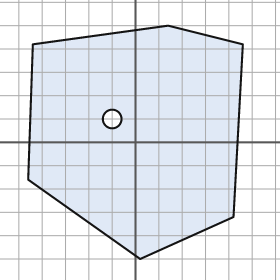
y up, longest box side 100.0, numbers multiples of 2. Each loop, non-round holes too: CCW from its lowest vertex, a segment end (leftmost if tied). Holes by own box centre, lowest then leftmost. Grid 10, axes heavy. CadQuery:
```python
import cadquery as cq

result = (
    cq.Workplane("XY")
    .moveTo(2.0, -50.0)
    .lineTo(42.0, -32.0)
    .lineTo(46.0, 42.0)
    .lineTo(14.0, 50.0)
    .lineTo(-44.0, 42.0)
    .lineTo(-46.0, -16.0)
    .close()
    .moveTo(-10.0, 10.0)
    .circle(4.0)
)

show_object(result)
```